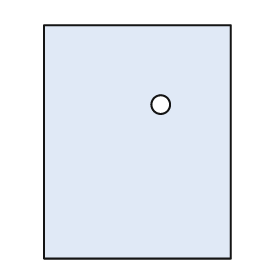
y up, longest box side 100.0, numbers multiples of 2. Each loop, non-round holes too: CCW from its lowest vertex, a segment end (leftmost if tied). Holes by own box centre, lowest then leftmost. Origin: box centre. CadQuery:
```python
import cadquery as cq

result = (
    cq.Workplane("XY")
    .moveTo(-40.0, -50.0)
    .lineTo(40.0, -50.0)
    .lineTo(40.0, 50.0)
    .lineTo(-40.0, 50.0)
    .close()
    .moveTo(10.0, 16.0)
    .circle(4.0)
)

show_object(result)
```